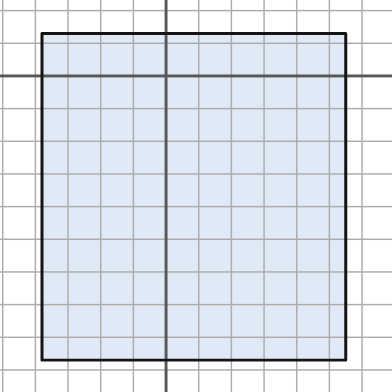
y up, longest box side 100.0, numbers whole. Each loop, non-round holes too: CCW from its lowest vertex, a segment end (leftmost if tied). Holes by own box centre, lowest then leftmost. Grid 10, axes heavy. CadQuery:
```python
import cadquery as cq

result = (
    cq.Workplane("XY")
    .moveTo(-38.0, -87.0)
    .lineTo(55.0, -87.0)
    .lineTo(55.0, 13.0)
    .lineTo(-38.0, 13.0)
    .close()
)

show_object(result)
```